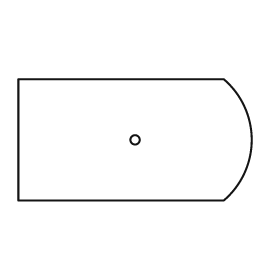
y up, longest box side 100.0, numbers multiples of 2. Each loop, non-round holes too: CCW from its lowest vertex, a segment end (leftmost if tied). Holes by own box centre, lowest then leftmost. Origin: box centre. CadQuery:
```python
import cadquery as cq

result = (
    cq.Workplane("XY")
    .moveTo(-50.0, -26.0)
    .lineTo(38.0, -26.0)
    .threePointArc((50.0, 0.0), (38.0, 26.0))
    .lineTo(-50.0, 26.0)
    .close()
    .moveTo(0.0, 0.0)
    .circle(2.0)
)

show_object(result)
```